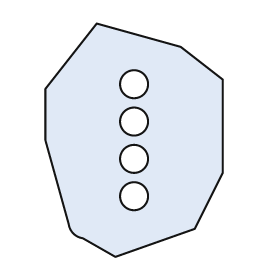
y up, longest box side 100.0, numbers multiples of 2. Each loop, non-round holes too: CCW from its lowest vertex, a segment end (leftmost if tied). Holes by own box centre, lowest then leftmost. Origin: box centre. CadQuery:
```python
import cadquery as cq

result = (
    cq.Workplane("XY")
    .moveTo(-8.0, -50.0)
    .lineTo(26.0, -38.0)
    .lineTo(38.0, -14.0)
    .lineTo(38.0, 26.0)
    .lineTo(20.0, 40.0)
    .lineTo(-16.0, 50.0)
    .lineTo(-38.0, 22.0)
    .lineTo(-38.0, 0.0)
    .lineTo(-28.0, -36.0)
    .threePointArc((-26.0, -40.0), (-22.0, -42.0))
    .close()
    .moveTo(0.0, -24.0)
    .circle(6.0)
    .moveTo(0.0, -8.0)
    .circle(6.0)
    .moveTo(0.0, 8.0)
    .circle(6.0)
    .moveTo(0.0, 24.0)
    .circle(6.0)
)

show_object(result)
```